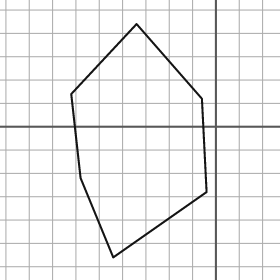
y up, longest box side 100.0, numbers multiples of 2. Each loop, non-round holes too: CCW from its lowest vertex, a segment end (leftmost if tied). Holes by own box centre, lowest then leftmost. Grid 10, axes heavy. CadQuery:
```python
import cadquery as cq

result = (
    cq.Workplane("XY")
    .moveTo(-44.0, -56.0)
    .lineTo(-4.0, -28.0)
    .lineTo(-6.0, 12.0)
    .lineTo(-34.0, 44.0)
    .lineTo(-62.0, 14.0)
    .lineTo(-58.0, -22.0)
    .close()
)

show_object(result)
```